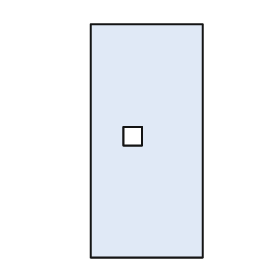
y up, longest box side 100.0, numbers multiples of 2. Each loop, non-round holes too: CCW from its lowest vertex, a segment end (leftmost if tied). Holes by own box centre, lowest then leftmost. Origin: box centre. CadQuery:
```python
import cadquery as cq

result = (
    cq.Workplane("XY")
    .moveTo(-24.0, -50.0)
    .lineTo(24.0, -50.0)
    .lineTo(24.0, 50.0)
    .lineTo(-24.0, 50.0)
    .close()
    .moveTo(-10.0, -2.0)
    .lineTo(-2.0, -2.0)
    .lineTo(-2.0, 6.0)
    .lineTo(-10.0, 6.0)
    .close()
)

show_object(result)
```